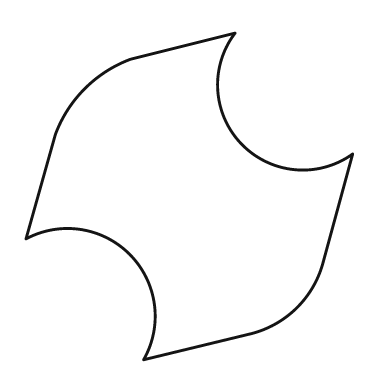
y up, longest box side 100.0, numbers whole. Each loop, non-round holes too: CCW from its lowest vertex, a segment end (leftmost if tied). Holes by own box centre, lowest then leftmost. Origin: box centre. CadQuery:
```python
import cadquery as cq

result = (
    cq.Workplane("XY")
    .moveTo(-14.0, -50.0)
    .lineTo(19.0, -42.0)
    .threePointArc((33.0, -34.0), (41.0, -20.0))
    .lineTo(50.0, 13.0)
    .threePointArc((16.0, 16.0), (14.0, 50.0))
    .lineTo(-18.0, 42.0)
    .threePointArc((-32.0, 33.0), (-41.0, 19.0))
    .lineTo(-50.0, -13.0)
    .threePointArc((-18.0, -18.0), (-14.0, -50.0))
    .close()
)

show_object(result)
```